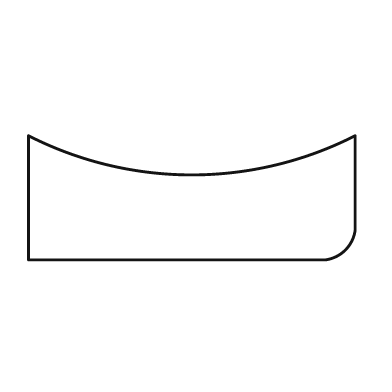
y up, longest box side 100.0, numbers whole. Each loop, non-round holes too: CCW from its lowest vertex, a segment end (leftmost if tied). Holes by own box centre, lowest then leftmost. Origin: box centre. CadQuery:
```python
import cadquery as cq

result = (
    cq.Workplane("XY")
    .moveTo(-50.0, -19.0)
    .lineTo(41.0, -19.0)
    .threePointArc((47.0, -16.0), (50.0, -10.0))
    .lineTo(50.0, 19.0)
    .threePointArc((0.0, 7.0), (-50.0, 19.0))
    .close()
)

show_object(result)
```